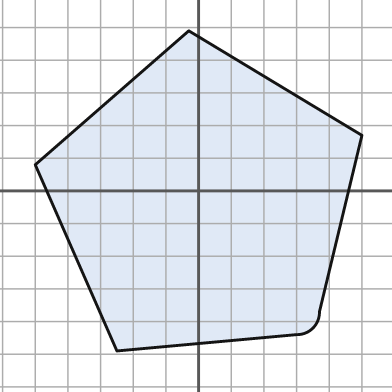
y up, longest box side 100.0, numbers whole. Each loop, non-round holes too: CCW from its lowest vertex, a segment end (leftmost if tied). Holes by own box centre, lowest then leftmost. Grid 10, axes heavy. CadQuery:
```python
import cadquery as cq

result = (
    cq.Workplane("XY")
    .moveTo(-25.0, -49.0)
    .lineTo(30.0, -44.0)
    .threePointArc((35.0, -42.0), (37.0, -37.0))
    .lineTo(50.0, 17.0)
    .lineTo(-3.0, 49.0)
    .lineTo(-50.0, 8.0)
    .close()
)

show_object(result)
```